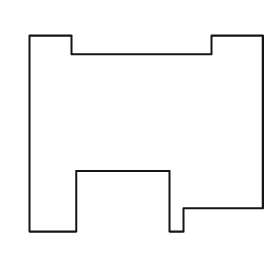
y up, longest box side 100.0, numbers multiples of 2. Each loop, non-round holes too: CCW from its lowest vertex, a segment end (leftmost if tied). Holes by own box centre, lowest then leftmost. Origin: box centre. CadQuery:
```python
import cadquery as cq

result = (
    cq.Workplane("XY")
    .moveTo(-50.0, -42.0)
    .lineTo(-30.0, -42.0)
    .lineTo(-30.0, -16.0)
    .lineTo(10.0, -16.0)
    .lineTo(10.0, -42.0)
    .lineTo(16.0, -42.0)
    .lineTo(16.0, -32.0)
    .lineTo(50.0, -32.0)
    .lineTo(50.0, 42.0)
    .lineTo(28.0, 42.0)
    .lineTo(28.0, 34.0)
    .lineTo(-32.0, 34.0)
    .lineTo(-32.0, 42.0)
    .lineTo(-50.0, 42.0)
    .close()
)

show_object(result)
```